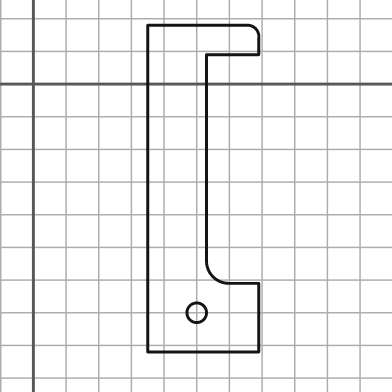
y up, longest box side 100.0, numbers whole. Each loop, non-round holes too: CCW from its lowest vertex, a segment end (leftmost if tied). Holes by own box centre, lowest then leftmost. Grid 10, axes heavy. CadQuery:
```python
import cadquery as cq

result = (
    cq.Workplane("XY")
    .moveTo(35.0, -82.0)
    .lineTo(69.0, -82.0)
    .lineTo(69.0, -61.0)
    .lineTo(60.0, -61.0)
    .threePointArc((55.0, -59.0), (53.0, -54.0))
    .lineTo(53.0, 9.0)
    .lineTo(69.0, 9.0)
    .lineTo(69.0, 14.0)
    .threePointArc((68.0, 17.0), (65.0, 18.0))
    .lineTo(35.0, 18.0)
    .close()
    .moveTo(50.0, -70.0)
    .circle(3.0)
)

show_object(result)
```